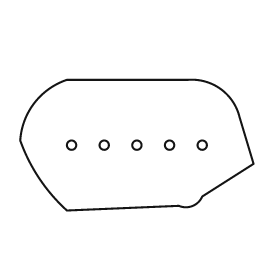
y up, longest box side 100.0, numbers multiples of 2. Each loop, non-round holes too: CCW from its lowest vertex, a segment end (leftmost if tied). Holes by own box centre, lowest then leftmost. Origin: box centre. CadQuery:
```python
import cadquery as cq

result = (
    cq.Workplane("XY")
    .moveTo(-30.0, -28.0)
    .lineTo(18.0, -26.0)
    .threePointArc((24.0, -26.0), (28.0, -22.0))
    .lineTo(50.0, -8.0)
    .lineTo(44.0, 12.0)
    .threePointArc((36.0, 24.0), (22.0, 28.0))
    .lineTo(-30.0, 28.0)
    .threePointArc((-44.0, 18.0), (-50.0, 2.0))
    .threePointArc((-42.0, -14.0), (-30.0, -28.0))
    .close()
    .moveTo(-28.0, 0.0)
    .circle(2.0)
    .moveTo(-14.0, 0.0)
    .circle(2.0)
    .moveTo(0.0, 0.0)
    .circle(2.0)
    .moveTo(14.0, 0.0)
    .circle(2.0)
    .moveTo(28.0, 0.0)
    .circle(2.0)
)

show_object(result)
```